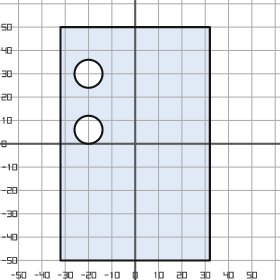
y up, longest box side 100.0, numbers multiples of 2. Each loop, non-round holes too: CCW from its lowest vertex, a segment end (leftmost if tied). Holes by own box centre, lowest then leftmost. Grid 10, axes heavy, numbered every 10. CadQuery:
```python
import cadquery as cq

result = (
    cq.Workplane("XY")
    .moveTo(-32.0, -50.0)
    .lineTo(32.0, -50.0)
    .lineTo(32.0, 50.0)
    .lineTo(-32.0, 50.0)
    .close()
    .moveTo(-20.0, 6.0)
    .circle(6.0)
    .moveTo(-20.0, 30.0)
    .circle(6.0)
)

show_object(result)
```